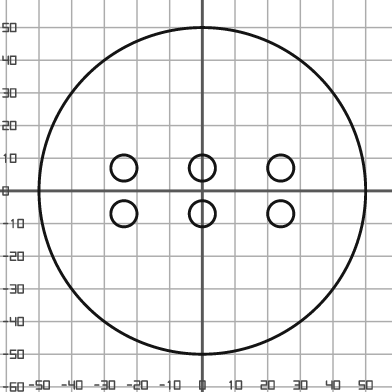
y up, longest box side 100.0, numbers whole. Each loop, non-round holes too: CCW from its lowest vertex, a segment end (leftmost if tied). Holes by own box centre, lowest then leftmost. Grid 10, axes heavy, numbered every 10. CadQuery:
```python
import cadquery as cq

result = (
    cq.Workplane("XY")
    .moveTo(0.0, 0.0)
    .circle(50.0)
    .moveTo(-24.0, -7.0)
    .circle(4.0)
    .moveTo(0.0, -7.0)
    .circle(4.0)
    .moveTo(24.0, -7.0)
    .circle(4.0)
    .moveTo(-24.0, 7.0)
    .circle(4.0)
    .moveTo(0.0, 7.0)
    .circle(4.0)
    .moveTo(24.0, 7.0)
    .circle(4.0)
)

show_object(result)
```